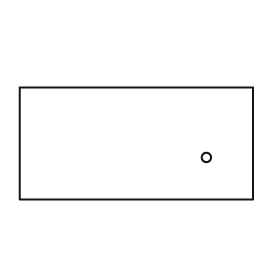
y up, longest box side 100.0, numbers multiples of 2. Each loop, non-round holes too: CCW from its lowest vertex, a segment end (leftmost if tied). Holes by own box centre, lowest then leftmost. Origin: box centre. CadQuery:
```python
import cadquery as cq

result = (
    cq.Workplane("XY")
    .moveTo(-50.0, -24.0)
    .lineTo(50.0, -24.0)
    .lineTo(50.0, 24.0)
    .lineTo(-50.0, 24.0)
    .close()
    .moveTo(30.0, -6.0)
    .circle(2.0)
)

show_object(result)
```